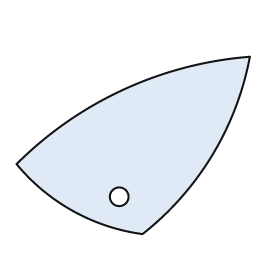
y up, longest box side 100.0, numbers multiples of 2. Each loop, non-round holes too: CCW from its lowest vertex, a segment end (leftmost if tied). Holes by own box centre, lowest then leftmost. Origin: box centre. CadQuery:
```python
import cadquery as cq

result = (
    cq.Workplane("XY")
    .moveTo(4.0, -38.0)
    .threePointArc((34.0, -4.0), (50.0, 38.0))
    .threePointArc((-4.0, 24.0), (-50.0, -8.0))
    .threePointArc((-26.0, -28.0), (4.0, -38.0))
    .close()
    .moveTo(-6.0, -22.0)
    .circle(4.0)
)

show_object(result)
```